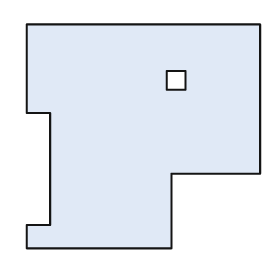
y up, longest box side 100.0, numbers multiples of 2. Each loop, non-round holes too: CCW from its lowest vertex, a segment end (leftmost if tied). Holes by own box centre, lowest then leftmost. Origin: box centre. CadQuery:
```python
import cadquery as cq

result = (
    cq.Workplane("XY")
    .moveTo(-50.0, -48.0)
    .lineTo(12.0, -48.0)
    .lineTo(12.0, -16.0)
    .lineTo(50.0, -16.0)
    .lineTo(50.0, 48.0)
    .lineTo(-50.0, 48.0)
    .lineTo(-50.0, 10.0)
    .lineTo(-40.0, 10.0)
    .lineTo(-40.0, -38.0)
    .lineTo(-50.0, -38.0)
    .close()
    .moveTo(10.0, 20.0)
    .lineTo(18.0, 20.0)
    .lineTo(18.0, 28.0)
    .lineTo(10.0, 28.0)
    .close()
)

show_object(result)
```